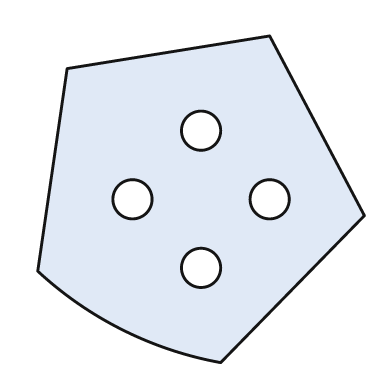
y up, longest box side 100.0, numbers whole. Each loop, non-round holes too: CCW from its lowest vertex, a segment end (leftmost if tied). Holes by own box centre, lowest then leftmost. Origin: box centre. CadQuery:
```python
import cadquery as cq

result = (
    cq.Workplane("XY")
    .moveTo(6.0, -50.0)
    .lineTo(50.0, -5.0)
    .lineTo(21.0, 50.0)
    .lineTo(-41.0, 40.0)
    .lineTo(-50.0, -22.0)
    .threePointArc((-24.0, -40.0), (6.0, -50.0))
    .close()
    .moveTo(0.0, -21.0)
    .circle(6.0)
    .moveTo(-21.0, 0.0)
    .circle(6.0)
    .moveTo(21.0, 0.0)
    .circle(6.0)
    .moveTo(0.0, 21.0)
    .circle(6.0)
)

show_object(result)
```